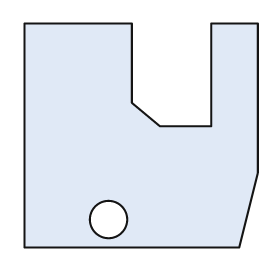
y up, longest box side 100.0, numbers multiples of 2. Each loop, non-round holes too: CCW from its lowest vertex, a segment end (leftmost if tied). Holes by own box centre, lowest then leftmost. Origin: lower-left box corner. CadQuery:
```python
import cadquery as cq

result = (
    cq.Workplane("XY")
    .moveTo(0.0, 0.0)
    .lineTo(92.0, 0.0)
    .lineTo(100.0, 32.0)
    .lineTo(100.0, 96.0)
    .lineTo(80.0, 96.0)
    .lineTo(80.0, 52.0)
    .lineTo(58.0, 52.0)
    .lineTo(46.0, 62.0)
    .lineTo(46.0, 96.0)
    .lineTo(0.0, 96.0)
    .close()
    .moveTo(36.0, 12.0)
    .circle(8.0)
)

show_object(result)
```